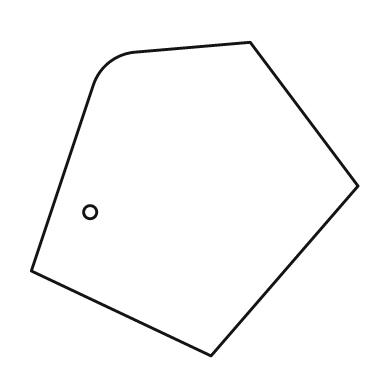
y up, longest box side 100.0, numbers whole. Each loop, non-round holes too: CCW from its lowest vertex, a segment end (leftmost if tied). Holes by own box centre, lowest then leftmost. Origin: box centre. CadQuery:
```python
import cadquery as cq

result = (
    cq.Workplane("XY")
    .moveTo(5.0, -48.0)
    .lineTo(50.0, 4.0)
    .lineTo(17.0, 48.0)
    .lineTo(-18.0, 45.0)
    .threePointArc((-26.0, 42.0), (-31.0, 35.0))
    .lineTo(-50.0, -22.0)
    .close()
    .moveTo(-32.0, -4.0)
    .circle(2.0)
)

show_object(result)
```